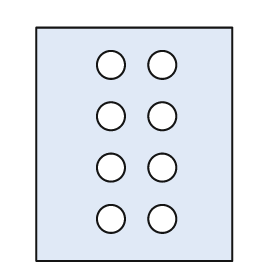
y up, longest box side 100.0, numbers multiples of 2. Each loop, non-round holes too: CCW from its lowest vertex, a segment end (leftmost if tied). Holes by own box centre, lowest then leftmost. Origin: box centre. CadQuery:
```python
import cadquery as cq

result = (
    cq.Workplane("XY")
    .moveTo(-42.0, -50.0)
    .lineTo(42.0, -50.0)
    .lineTo(42.0, 50.0)
    .lineTo(-42.0, 50.0)
    .close()
    .moveTo(-10.0, -32.0)
    .circle(6.0)
    .moveTo(12.0, -32.0)
    .circle(6.0)
    .moveTo(-10.0, -10.0)
    .circle(6.0)
    .moveTo(12.0, -10.0)
    .circle(6.0)
    .moveTo(-10.0, 12.0)
    .circle(6.0)
    .moveTo(12.0, 12.0)
    .circle(6.0)
    .moveTo(-10.0, 34.0)
    .circle(6.0)
    .moveTo(12.0, 34.0)
    .circle(6.0)
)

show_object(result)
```